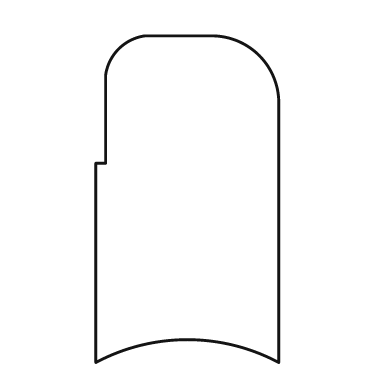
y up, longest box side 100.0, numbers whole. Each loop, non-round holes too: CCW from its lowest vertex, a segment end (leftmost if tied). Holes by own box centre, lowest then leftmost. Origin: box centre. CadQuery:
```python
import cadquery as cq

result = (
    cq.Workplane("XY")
    .moveTo(-28.0, -50.0)
    .threePointArc((0.0, -43.0), (28.0, -50.0))
    .lineTo(28.0, 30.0)
    .threePointArc((22.0, 44.0), (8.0, 50.0))
    .lineTo(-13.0, 50.0)
    .threePointArc((-21.0, 46.0), (-25.0, 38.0))
    .lineTo(-25.0, 11.0)
    .lineTo(-28.0, 11.0)
    .close()
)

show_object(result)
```